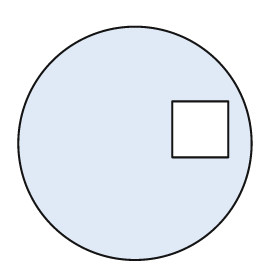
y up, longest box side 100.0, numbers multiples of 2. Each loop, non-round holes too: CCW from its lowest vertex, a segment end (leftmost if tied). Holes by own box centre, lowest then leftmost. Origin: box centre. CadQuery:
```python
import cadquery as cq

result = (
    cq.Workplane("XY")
    .moveTo(0.0, 0.0)
    .circle(50.0)
    .moveTo(16.0, -6.0)
    .lineTo(40.0, -6.0)
    .lineTo(40.0, 18.0)
    .lineTo(16.0, 18.0)
    .close()
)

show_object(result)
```